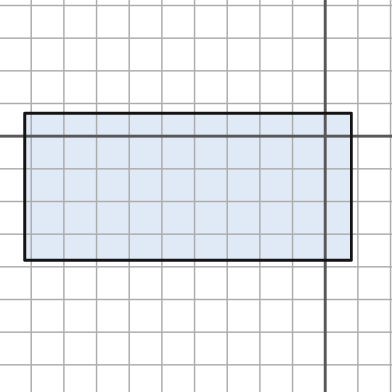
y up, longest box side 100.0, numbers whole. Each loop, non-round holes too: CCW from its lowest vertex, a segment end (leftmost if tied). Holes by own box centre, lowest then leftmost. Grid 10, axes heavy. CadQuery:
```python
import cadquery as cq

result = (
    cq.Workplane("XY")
    .moveTo(-92.0, -38.0)
    .lineTo(8.0, -38.0)
    .lineTo(8.0, 7.0)
    .lineTo(-92.0, 7.0)
    .close()
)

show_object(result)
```